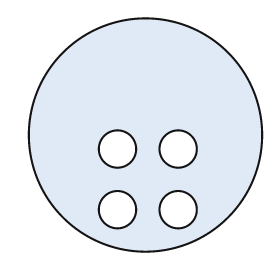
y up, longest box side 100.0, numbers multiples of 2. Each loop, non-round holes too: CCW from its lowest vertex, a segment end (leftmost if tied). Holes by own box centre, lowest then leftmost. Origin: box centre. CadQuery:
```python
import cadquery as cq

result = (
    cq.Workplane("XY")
    .moveTo(0.0, 0.0)
    .circle(50.0)
    .moveTo(-12.0, -32.0)
    .circle(8.0)
    .moveTo(14.0, -32.0)
    .circle(8.0)
    .moveTo(-12.0, -6.0)
    .circle(8.0)
    .moveTo(14.0, -6.0)
    .circle(8.0)
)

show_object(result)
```